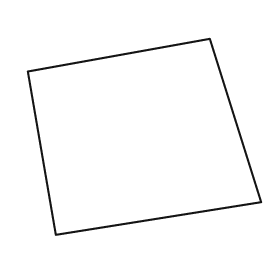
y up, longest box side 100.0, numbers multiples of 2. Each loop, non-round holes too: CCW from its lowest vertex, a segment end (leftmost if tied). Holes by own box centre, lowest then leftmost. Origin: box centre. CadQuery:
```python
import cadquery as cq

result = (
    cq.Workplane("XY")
    .moveTo(-38.0, -42.0)
    .lineTo(50.0, -28.0)
    .lineTo(28.0, 42.0)
    .lineTo(-50.0, 28.0)
    .close()
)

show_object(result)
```